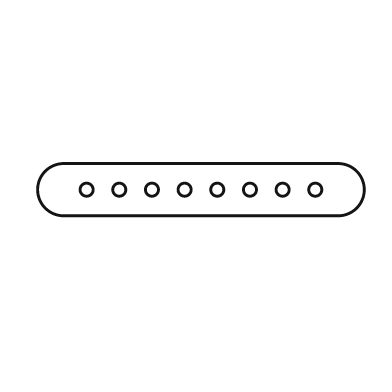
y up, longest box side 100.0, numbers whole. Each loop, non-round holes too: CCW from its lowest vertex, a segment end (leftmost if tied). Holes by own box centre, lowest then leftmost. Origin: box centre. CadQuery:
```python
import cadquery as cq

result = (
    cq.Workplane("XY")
    .moveTo(-42.0, -8.0)
    .lineTo(42.0, -8.0)
    .threePointArc((50.0, 0.0), (42.0, 8.0))
    .lineTo(-42.0, 8.0)
    .threePointArc((-50.0, 0.0), (-42.0, -8.0))
    .close()
    .moveTo(-35.0, 0.0)
    .circle(2.0)
    .moveTo(-25.0, 0.0)
    .circle(2.0)
    .moveTo(-15.0, 0.0)
    .circle(2.0)
    .moveTo(-5.0, 0.0)
    .circle(2.0)
    .moveTo(5.0, 0.0)
    .circle(2.0)
    .moveTo(15.0, 0.0)
    .circle(2.0)
    .moveTo(25.0, 0.0)
    .circle(2.0)
    .moveTo(35.0, 0.0)
    .circle(2.0)
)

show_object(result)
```